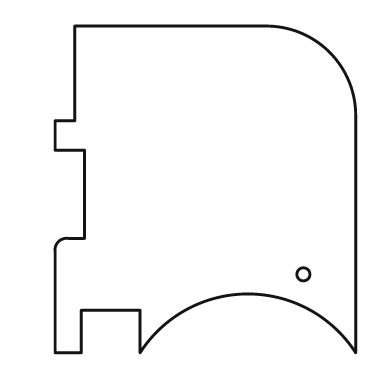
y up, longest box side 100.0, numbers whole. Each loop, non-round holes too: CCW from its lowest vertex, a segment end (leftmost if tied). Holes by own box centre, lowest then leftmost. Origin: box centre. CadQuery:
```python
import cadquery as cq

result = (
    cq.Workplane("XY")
    .moveTo(-46.0, -50.0)
    .lineTo(-38.0, -50.0)
    .lineTo(-38.0, -37.0)
    .lineTo(-20.0, -37.0)
    .lineTo(-20.0, -50.0)
    .threePointArc((13.0, -32.0), (46.0, -50.0))
    .lineTo(46.0, 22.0)
    .threePointArc((38.0, 42.0), (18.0, 50.0))
    .lineTo(-40.0, 50.0)
    .lineTo(-40.0, 21.0)
    .lineTo(-46.0, 21.0)
    .lineTo(-46.0, 12.0)
    .lineTo(-37.0, 12.0)
    .lineTo(-37.0, -15.0)
    .lineTo(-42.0, -15.0)
    .threePointArc((-45.0, -16.0), (-46.0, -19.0))
    .close()
    .moveTo(30.0, -26.0)
    .circle(2.0)
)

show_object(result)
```